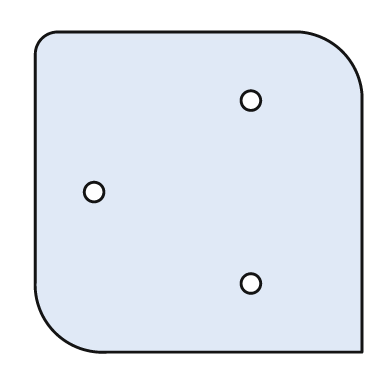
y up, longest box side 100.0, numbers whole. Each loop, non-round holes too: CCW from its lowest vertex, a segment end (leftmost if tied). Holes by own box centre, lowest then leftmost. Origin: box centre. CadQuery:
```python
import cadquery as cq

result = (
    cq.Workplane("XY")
    .moveTo(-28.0, -49.0)
    .lineTo(50.0, -49.0)
    .lineTo(50.0, 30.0)
    .threePointArc((44.0, 43.0), (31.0, 49.0))
    .lineTo(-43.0, 49.0)
    .threePointArc((-48.0, 47.0), (-50.0, 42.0))
    .lineTo(-50.0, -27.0)
    .threePointArc((-44.0, -43.0), (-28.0, -49.0))
    .close()
    .moveTo(16.0, -28.0)
    .circle(3.0)
    .moveTo(-32.0, 0.0)
    .circle(3.0)
    .moveTo(16.0, 28.0)
    .circle(3.0)
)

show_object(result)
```